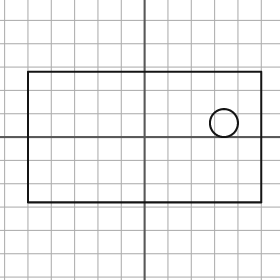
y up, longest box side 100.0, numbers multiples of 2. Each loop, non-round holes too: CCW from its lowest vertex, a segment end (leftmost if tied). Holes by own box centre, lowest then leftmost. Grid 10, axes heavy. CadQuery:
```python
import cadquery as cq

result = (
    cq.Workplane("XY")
    .moveTo(-50.0, -28.0)
    .lineTo(50.0, -28.0)
    .lineTo(50.0, 28.0)
    .lineTo(-50.0, 28.0)
    .close()
    .moveTo(34.0, 6.0)
    .circle(6.0)
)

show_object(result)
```